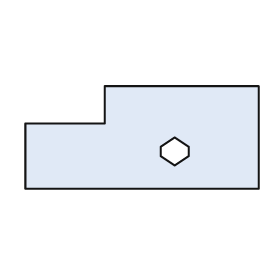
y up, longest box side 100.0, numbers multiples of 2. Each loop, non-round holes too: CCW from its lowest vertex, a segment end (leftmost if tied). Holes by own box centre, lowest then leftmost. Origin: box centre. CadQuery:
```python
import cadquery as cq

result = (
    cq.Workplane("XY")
    .moveTo(-50.0, -22.0)
    .lineTo(50.0, -22.0)
    .lineTo(50.0, 22.0)
    .lineTo(-16.0, 22.0)
    .lineTo(-16.0, 6.0)
    .lineTo(-50.0, 6.0)
    .close()
    .moveTo(14.0, -12.0)
    .lineTo(20.0, -8.0)
    .lineTo(20.0, -4.0)
    .lineTo(14.0, 0.0)
    .lineTo(8.0, -4.0)
    .lineTo(8.0, -8.0)
    .close()
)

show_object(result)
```